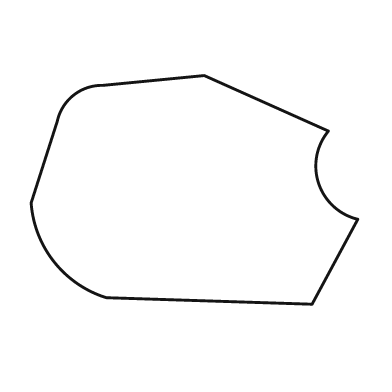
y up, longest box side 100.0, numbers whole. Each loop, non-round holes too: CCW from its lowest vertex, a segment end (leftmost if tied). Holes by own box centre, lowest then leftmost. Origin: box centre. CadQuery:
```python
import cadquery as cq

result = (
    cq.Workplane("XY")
    .moveTo(36.0, -35.0)
    .lineTo(50.0, -9.0)
    .threePointArc((38.0, 2.0), (41.0, 18.0))
    .lineTo(3.0, 35.0)
    .lineTo(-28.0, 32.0)
    .threePointArc((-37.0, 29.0), (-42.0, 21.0))
    .lineTo(-50.0, -4.0)
    .threePointArc((-43.0, -22.0), (-27.0, -33.0))
    .close()
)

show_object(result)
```